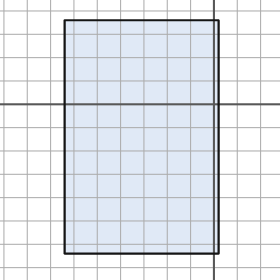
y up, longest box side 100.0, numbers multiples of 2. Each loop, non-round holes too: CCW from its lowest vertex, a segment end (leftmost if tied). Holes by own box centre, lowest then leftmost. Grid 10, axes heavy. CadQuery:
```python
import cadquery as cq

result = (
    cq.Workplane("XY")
    .moveTo(-64.0, -64.0)
    .lineTo(2.0, -64.0)
    .lineTo(2.0, 36.0)
    .lineTo(-64.0, 36.0)
    .close()
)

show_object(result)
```